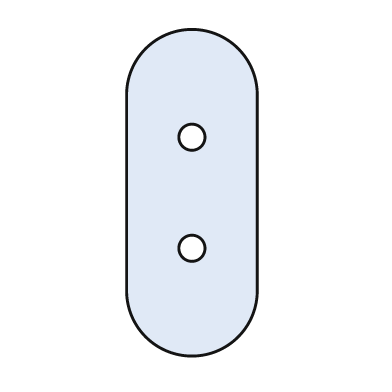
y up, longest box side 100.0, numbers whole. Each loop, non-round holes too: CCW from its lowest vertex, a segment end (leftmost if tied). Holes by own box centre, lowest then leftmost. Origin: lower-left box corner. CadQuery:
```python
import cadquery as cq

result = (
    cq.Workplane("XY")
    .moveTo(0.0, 20.0)
    .threePointArc((20.0, 0.0), (40.0, 20.0))
    .lineTo(40.0, 80.0)
    .threePointArc((20.0, 100.0), (0.0, 80.0))
    .close()
    .moveTo(20.0, 33.0)
    .circle(4.0)
    .moveTo(20.0, 67.0)
    .circle(4.0)
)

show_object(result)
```